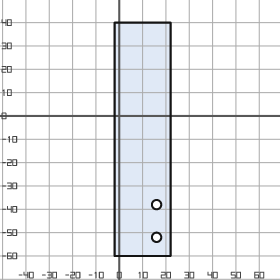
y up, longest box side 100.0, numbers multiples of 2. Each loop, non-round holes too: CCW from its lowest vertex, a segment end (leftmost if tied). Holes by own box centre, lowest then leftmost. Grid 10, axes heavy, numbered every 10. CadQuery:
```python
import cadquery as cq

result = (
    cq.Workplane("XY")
    .moveTo(-2.0, -60.0)
    .lineTo(22.0, -60.0)
    .lineTo(22.0, 40.0)
    .lineTo(-2.0, 40.0)
    .close()
    .moveTo(16.0, -52.0)
    .circle(2.0)
    .moveTo(16.0, -38.0)
    .circle(2.0)
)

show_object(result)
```